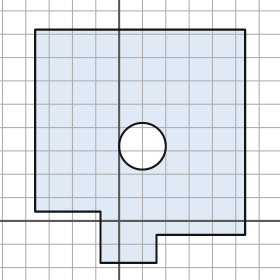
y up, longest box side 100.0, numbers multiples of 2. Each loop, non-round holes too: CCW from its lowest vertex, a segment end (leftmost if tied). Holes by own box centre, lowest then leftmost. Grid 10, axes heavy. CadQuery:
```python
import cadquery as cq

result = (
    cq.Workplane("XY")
    .moveTo(-8.0, -18.0)
    .lineTo(16.0, -18.0)
    .lineTo(16.0, -6.0)
    .lineTo(54.0, -6.0)
    .lineTo(54.0, 82.0)
    .lineTo(-36.0, 82.0)
    .lineTo(-36.0, 4.0)
    .lineTo(-8.0, 4.0)
    .close()
    .moveTo(10.0, 32.0)
    .circle(10.0)
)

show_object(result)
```